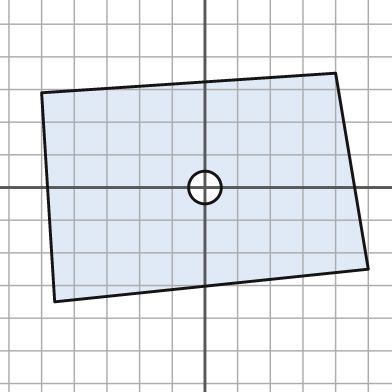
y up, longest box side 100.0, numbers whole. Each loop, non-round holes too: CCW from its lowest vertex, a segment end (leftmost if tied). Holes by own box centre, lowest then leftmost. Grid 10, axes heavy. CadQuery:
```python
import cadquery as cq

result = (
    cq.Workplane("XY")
    .moveTo(-46.0, -35.0)
    .lineTo(50.0, -25.0)
    .lineTo(40.0, 35.0)
    .lineTo(-50.0, 29.0)
    .close()
    .moveTo(0.0, 0.0)
    .circle(5.0)
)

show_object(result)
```